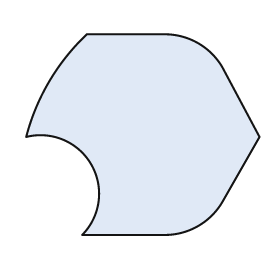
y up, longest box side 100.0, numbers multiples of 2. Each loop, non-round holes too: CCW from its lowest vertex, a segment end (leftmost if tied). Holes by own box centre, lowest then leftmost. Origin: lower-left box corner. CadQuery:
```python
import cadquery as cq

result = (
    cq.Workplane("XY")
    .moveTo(24.0, 0.0)
    .lineTo(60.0, 0.0)
    .threePointArc((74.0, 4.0), (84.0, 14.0))
    .lineTo(100.0, 42.0)
    .lineTo(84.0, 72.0)
    .threePointArc((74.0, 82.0), (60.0, 86.0))
    .lineTo(26.0, 86.0)
    .threePointArc((10.0, 66.0), (0.0, 42.0))
    .threePointArc((28.0, 30.0), (24.0, 0.0))
    .close()
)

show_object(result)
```